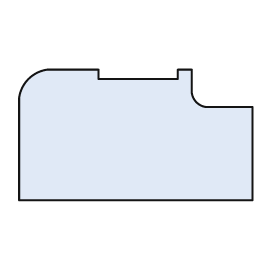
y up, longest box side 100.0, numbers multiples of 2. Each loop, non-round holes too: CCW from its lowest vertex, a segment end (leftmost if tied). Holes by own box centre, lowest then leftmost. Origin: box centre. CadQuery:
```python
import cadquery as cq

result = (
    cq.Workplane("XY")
    .moveTo(-50.0, -28.0)
    .lineTo(50.0, -28.0)
    .lineTo(50.0, 12.0)
    .lineTo(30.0, 12.0)
    .threePointArc((26.0, 14.0), (24.0, 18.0))
    .lineTo(24.0, 28.0)
    .lineTo(18.0, 28.0)
    .lineTo(18.0, 24.0)
    .lineTo(-16.0, 24.0)
    .lineTo(-16.0, 28.0)
    .lineTo(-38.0, 28.0)
    .threePointArc((-46.0, 24.0), (-50.0, 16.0))
    .close()
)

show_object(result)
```